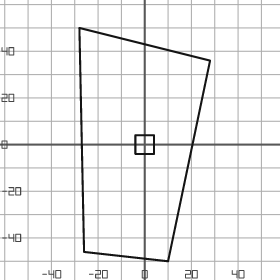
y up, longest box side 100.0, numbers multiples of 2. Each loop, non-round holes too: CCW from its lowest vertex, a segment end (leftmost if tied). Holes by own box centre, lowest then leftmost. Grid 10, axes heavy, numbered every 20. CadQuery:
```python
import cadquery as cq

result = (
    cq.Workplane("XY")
    .moveTo(10.0, -50.0)
    .lineTo(28.0, 36.0)
    .lineTo(-28.0, 50.0)
    .lineTo(-26.0, -46.0)
    .close()
    .moveTo(-4.0, -4.0)
    .lineTo(4.0, -4.0)
    .lineTo(4.0, 4.0)
    .lineTo(-4.0, 4.0)
    .close()
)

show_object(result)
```